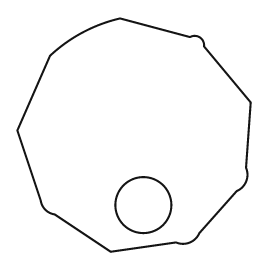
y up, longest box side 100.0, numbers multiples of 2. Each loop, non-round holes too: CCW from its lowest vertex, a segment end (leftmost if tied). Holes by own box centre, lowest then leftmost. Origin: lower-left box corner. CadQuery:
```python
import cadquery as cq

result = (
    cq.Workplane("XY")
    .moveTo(40.0, 0.0)
    .lineTo(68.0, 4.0)
    .threePointArc((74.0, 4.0), (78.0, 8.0))
    .lineTo(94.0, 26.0)
    .threePointArc((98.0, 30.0), (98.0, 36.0))
    .lineTo(100.0, 64.0)
    .lineTo(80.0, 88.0)
    .threePointArc((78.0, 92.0), (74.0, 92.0))
    .lineTo(44.0, 100.0)
    .threePointArc((28.0, 94.0), (14.0, 84.0))
    .lineTo(0.0, 52.0)
    .lineTo(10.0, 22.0)
    .threePointArc((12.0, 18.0), (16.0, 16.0))
    .close()
    .moveTo(54.0, 20.0)
    .circle(12.0)
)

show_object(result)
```